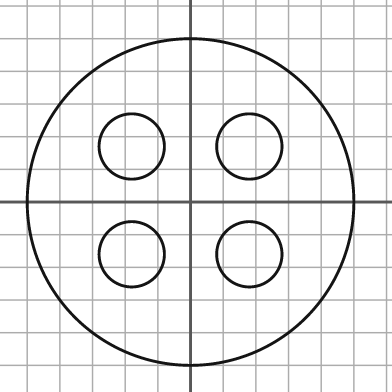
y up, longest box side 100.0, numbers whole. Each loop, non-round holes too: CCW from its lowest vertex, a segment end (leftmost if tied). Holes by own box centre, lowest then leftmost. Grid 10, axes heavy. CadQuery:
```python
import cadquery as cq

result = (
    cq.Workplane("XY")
    .moveTo(0.0, 0.0)
    .circle(50.0)
    .moveTo(-18.0, -16.0)
    .circle(10.0)
    .moveTo(18.0, -16.0)
    .circle(10.0)
    .moveTo(-18.0, 17.0)
    .circle(10.0)
    .moveTo(18.0, 17.0)
    .circle(10.0)
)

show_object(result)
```